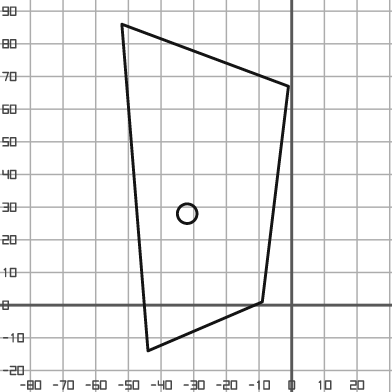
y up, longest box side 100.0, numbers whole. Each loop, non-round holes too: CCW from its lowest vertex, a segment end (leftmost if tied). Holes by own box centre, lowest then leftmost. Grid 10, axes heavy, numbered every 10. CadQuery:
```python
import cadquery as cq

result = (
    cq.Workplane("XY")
    .moveTo(-44.0, -14.0)
    .lineTo(-9.0, 1.0)
    .lineTo(-1.0, 67.0)
    .lineTo(-52.0, 86.0)
    .close()
    .moveTo(-32.0, 28.0)
    .circle(3.0)
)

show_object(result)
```